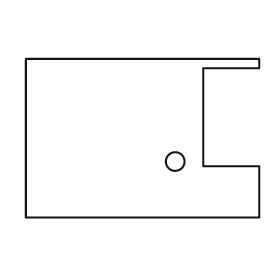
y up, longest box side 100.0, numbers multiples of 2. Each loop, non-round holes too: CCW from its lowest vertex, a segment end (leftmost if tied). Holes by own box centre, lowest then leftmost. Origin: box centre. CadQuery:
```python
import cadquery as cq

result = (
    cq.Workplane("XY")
    .moveTo(-50.0, -34.0)
    .lineTo(50.0, -34.0)
    .lineTo(50.0, -12.0)
    .lineTo(26.0, -12.0)
    .lineTo(26.0, 30.0)
    .lineTo(50.0, 30.0)
    .lineTo(50.0, 34.0)
    .lineTo(-50.0, 34.0)
    .close()
    .moveTo(14.0, -10.0)
    .circle(4.0)
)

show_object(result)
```